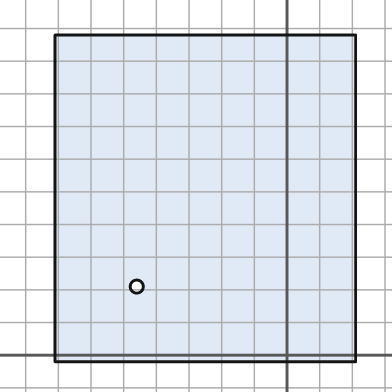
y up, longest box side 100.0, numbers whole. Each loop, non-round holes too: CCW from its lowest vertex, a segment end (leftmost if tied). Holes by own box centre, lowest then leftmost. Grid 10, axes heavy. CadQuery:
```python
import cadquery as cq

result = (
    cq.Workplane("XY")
    .moveTo(-71.0, -2.0)
    .lineTo(21.0, -2.0)
    .lineTo(21.0, 98.0)
    .lineTo(-71.0, 98.0)
    .close()
    .moveTo(-46.0, 21.0)
    .circle(2.0)
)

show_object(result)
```